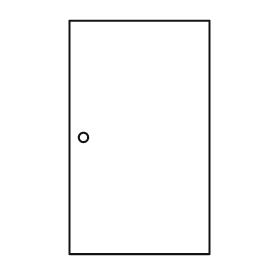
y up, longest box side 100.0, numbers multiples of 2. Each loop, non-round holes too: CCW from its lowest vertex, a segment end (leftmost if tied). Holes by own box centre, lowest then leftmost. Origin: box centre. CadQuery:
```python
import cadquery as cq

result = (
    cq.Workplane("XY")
    .moveTo(-30.0, -50.0)
    .lineTo(30.0, -50.0)
    .lineTo(30.0, 50.0)
    .lineTo(-30.0, 50.0)
    .close()
    .moveTo(-24.0, 0.0)
    .circle(2.0)
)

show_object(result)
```